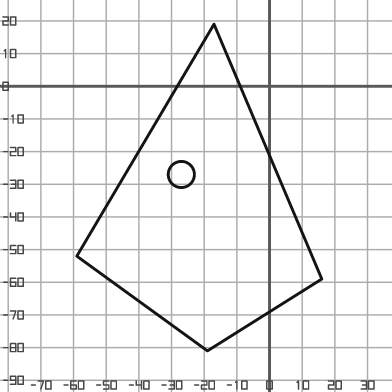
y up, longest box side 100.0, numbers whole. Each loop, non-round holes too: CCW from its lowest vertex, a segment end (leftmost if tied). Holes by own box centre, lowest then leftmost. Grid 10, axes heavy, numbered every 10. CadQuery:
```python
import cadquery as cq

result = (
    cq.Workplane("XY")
    .moveTo(-19.0, -81.0)
    .lineTo(16.0, -59.0)
    .lineTo(-17.0, 19.0)
    .lineTo(-59.0, -52.0)
    .close()
    .moveTo(-27.0, -27.0)
    .circle(4.0)
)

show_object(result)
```